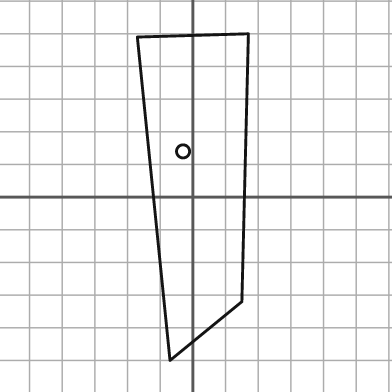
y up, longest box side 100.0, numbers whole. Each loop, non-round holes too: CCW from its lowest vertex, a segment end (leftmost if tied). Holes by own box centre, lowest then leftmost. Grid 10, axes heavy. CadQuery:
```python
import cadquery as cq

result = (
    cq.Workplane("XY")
    .moveTo(-7.0, -50.0)
    .lineTo(15.0, -32.0)
    .lineTo(17.0, 50.0)
    .lineTo(-17.0, 49.0)
    .close()
    .moveTo(-3.0, 14.0)
    .circle(2.0)
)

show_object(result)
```